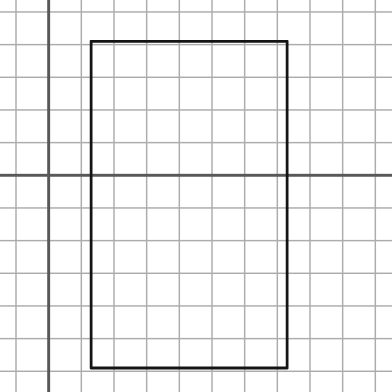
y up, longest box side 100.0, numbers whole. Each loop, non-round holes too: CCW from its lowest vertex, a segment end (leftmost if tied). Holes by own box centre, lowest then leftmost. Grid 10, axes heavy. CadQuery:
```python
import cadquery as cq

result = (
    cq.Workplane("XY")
    .moveTo(13.0, -59.0)
    .lineTo(73.0, -59.0)
    .lineTo(73.0, 41.0)
    .lineTo(13.0, 41.0)
    .close()
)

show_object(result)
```